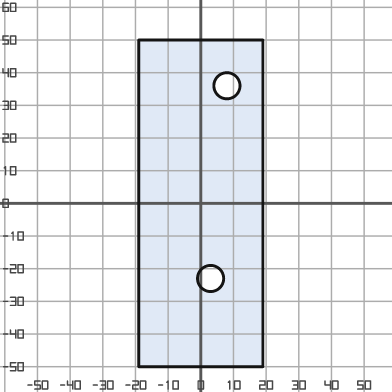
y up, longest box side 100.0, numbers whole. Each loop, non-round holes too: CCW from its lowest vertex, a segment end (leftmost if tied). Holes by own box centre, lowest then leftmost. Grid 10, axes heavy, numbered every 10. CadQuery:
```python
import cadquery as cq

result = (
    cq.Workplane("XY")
    .moveTo(-19.0, -50.0)
    .lineTo(19.0, -50.0)
    .lineTo(19.0, 50.0)
    .lineTo(-19.0, 50.0)
    .close()
    .moveTo(3.0, -23.0)
    .circle(4.0)
    .moveTo(8.0, 36.0)
    .circle(4.0)
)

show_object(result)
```